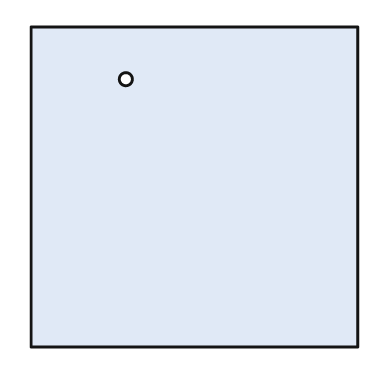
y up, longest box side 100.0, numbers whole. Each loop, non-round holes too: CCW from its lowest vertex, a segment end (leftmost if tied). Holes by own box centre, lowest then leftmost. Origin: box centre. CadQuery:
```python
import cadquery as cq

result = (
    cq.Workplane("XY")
    .moveTo(-50.0, -49.0)
    .lineTo(50.0, -49.0)
    .lineTo(50.0, 49.0)
    .lineTo(-50.0, 49.0)
    .close()
    .moveTo(-21.0, 33.0)
    .circle(2.0)
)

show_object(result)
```